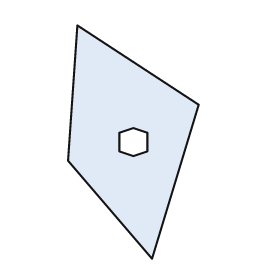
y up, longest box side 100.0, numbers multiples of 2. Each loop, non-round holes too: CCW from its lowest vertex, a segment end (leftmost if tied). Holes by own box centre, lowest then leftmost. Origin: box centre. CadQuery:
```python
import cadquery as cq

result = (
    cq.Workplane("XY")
    .moveTo(8.0, -50.0)
    .lineTo(28.0, 16.0)
    .lineTo(-24.0, 50.0)
    .lineTo(-28.0, -8.0)
    .close()
    .moveTo(0.0, -6.0)
    .lineTo(6.0, -4.0)
    .lineTo(6.0, 4.0)
    .lineTo(0.0, 6.0)
    .lineTo(-6.0, 4.0)
    .lineTo(-6.0, -4.0)
    .close()
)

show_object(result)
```